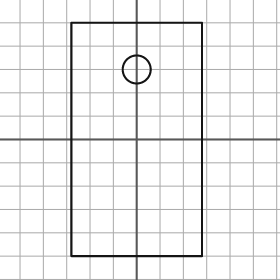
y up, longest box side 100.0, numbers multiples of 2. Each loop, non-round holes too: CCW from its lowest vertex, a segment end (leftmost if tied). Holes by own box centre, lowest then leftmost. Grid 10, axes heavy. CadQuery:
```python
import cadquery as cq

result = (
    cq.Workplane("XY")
    .moveTo(-28.0, -50.0)
    .lineTo(28.0, -50.0)
    .lineTo(28.0, 50.0)
    .lineTo(-28.0, 50.0)
    .close()
    .moveTo(0.0, 30.0)
    .circle(6.0)
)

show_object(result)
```